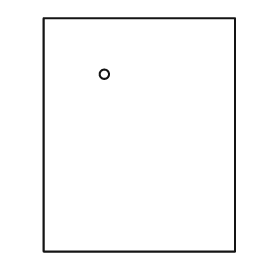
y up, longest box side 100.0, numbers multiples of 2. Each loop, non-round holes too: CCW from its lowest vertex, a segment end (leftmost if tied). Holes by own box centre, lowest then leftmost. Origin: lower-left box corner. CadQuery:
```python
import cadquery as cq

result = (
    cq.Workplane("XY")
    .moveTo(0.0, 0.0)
    .lineTo(82.0, 0.0)
    .lineTo(82.0, 100.0)
    .lineTo(0.0, 100.0)
    .close()
    .moveTo(26.0, 76.0)
    .circle(2.0)
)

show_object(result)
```